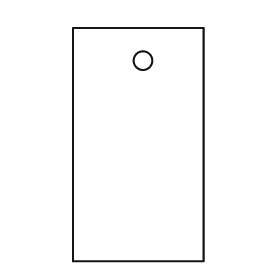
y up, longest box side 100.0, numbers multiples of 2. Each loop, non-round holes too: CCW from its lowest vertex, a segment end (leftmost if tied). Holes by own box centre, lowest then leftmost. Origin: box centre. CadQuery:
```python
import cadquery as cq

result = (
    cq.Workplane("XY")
    .moveTo(-28.0, -50.0)
    .lineTo(28.0, -50.0)
    .lineTo(28.0, 50.0)
    .lineTo(-28.0, 50.0)
    .close()
    .moveTo(2.0, 36.0)
    .circle(4.0)
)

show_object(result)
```